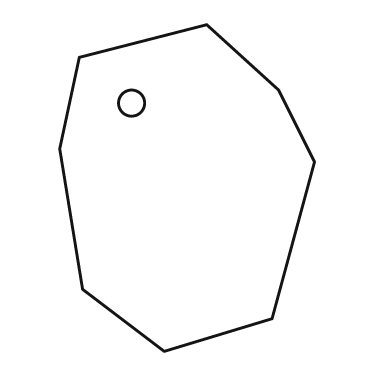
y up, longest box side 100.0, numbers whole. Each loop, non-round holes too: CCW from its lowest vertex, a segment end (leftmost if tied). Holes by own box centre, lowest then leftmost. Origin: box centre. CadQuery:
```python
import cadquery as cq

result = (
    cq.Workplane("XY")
    .moveTo(-7.0, -50.0)
    .lineTo(26.0, -40.0)
    .lineTo(39.0, 8.0)
    .lineTo(28.0, 30.0)
    .lineTo(6.0, 50.0)
    .lineTo(-33.0, 40.0)
    .lineTo(-39.0, 12.0)
    .lineTo(-32.0, -31.0)
    .close()
    .moveTo(-17.0, 26.0)
    .circle(4.0)
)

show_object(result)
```